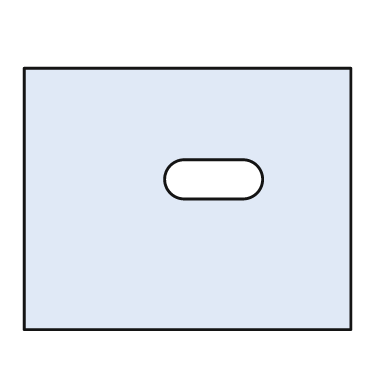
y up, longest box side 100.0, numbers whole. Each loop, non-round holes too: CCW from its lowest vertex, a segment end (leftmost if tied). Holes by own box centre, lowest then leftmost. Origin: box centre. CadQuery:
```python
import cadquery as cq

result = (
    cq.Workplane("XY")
    .moveTo(-50.0, -40.0)
    .lineTo(50.0, -40.0)
    .lineTo(50.0, 40.0)
    .lineTo(-50.0, 40.0)
    .close()
    .moveTo(-1.0, 0.0)
    .lineTo(17.0, 0.0)
    .threePointArc((23.0, 6.0), (17.0, 12.0))
    .lineTo(-1.0, 12.0)
    .threePointArc((-7.0, 6.0), (-1.0, 0.0))
    .close()
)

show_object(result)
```